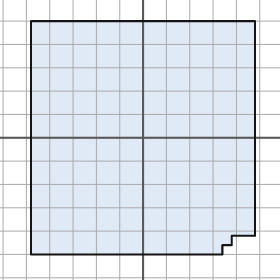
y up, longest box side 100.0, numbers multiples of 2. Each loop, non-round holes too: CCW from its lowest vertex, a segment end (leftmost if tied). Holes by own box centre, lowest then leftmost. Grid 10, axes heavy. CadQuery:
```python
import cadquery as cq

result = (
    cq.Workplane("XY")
    .moveTo(-48.0, -50.0)
    .lineTo(34.0, -50.0)
    .lineTo(34.0, -46.0)
    .lineTo(38.0, -46.0)
    .lineTo(38.0, -42.0)
    .lineTo(48.0, -42.0)
    .lineTo(48.0, 50.0)
    .lineTo(-48.0, 50.0)
    .close()
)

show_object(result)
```